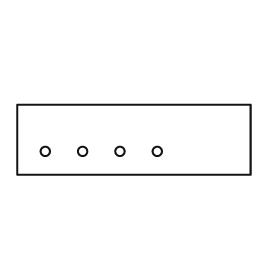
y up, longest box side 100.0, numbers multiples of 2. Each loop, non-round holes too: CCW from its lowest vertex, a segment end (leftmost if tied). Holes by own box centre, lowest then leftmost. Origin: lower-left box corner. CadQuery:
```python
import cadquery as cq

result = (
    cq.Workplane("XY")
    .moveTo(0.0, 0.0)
    .lineTo(100.0, 0.0)
    .lineTo(100.0, 30.0)
    .lineTo(0.0, 30.0)
    .close()
    .moveTo(12.0, 10.0)
    .circle(2.0)
    .moveTo(28.0, 10.0)
    .circle(2.0)
    .moveTo(44.0, 10.0)
    .circle(2.0)
    .moveTo(60.0, 10.0)
    .circle(2.0)
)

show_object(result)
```